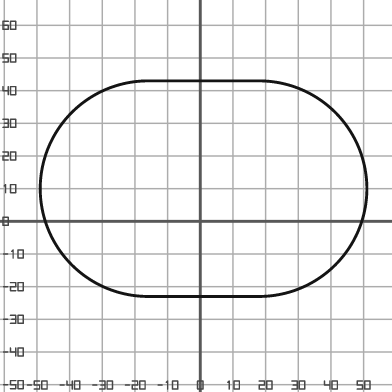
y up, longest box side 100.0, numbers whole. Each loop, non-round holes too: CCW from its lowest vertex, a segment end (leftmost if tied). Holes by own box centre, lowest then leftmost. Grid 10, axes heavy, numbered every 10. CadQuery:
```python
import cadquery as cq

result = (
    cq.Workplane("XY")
    .moveTo(-16.0, -23.0)
    .lineTo(18.0, -23.0)
    .threePointArc((51.0, 10.0), (18.0, 43.0))
    .lineTo(-16.0, 43.0)
    .threePointArc((-49.0, 10.0), (-16.0, -23.0))
    .close()
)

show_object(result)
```